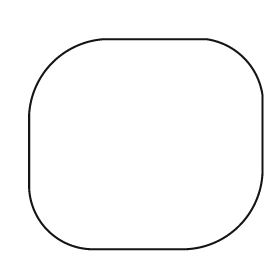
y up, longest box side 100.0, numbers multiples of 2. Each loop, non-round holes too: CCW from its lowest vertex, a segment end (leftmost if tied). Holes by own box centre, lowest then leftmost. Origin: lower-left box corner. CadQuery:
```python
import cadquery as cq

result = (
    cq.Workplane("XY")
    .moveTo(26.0, 0.0)
    .lineTo(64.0, 0.0)
    .threePointArc((90.0, 10.0), (100.0, 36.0))
    .lineTo(100.0, 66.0)
    .threePointArc((92.0, 82.0), (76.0, 90.0))
    .lineTo(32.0, 90.0)
    .threePointArc((10.0, 80.0), (0.0, 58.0))
    .lineTo(0.0, 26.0)
    .threePointArc((8.0, 8.0), (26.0, 0.0))
    .close()
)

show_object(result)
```